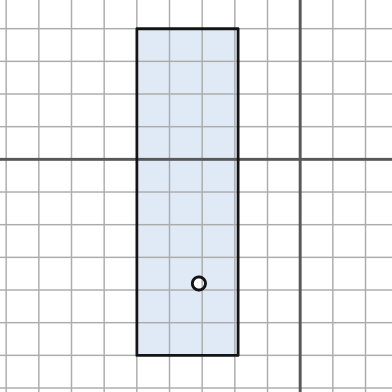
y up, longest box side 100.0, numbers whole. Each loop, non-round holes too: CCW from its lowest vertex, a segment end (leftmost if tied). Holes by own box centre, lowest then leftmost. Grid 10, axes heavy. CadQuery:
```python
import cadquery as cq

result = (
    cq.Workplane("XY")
    .moveTo(-50.0, -60.0)
    .lineTo(-19.0, -60.0)
    .lineTo(-19.0, 40.0)
    .lineTo(-50.0, 40.0)
    .close()
    .moveTo(-31.0, -38.0)
    .circle(2.0)
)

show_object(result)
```